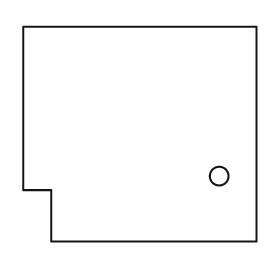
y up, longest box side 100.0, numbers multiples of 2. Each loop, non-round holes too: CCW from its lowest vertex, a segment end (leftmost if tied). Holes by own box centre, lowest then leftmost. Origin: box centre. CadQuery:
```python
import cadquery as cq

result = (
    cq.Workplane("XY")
    .moveTo(-38.0, -46.0)
    .lineTo(50.0, -46.0)
    .lineTo(50.0, 46.0)
    .lineTo(-50.0, 46.0)
    .lineTo(-50.0, -24.0)
    .lineTo(-38.0, -24.0)
    .close()
    .moveTo(34.0, -18.0)
    .circle(4.0)
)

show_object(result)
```